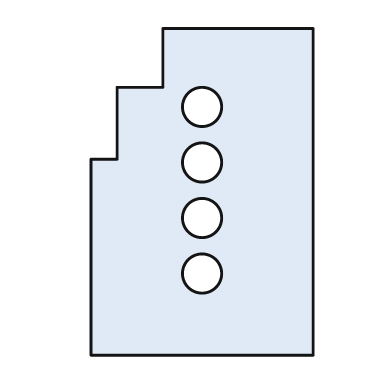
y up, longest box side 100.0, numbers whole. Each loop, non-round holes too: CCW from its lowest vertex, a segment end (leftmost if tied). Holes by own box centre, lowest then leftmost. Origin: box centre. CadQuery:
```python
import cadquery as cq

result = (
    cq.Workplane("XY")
    .moveTo(-34.0, -50.0)
    .lineTo(34.0, -50.0)
    .lineTo(34.0, 50.0)
    .lineTo(-12.0, 50.0)
    .lineTo(-12.0, 32.0)
    .lineTo(-26.0, 32.0)
    .lineTo(-26.0, 10.0)
    .lineTo(-34.0, 10.0)
    .close()
    .moveTo(0.0, -25.0)
    .circle(6.0)
    .moveTo(0.0, -8.0)
    .circle(6.0)
    .moveTo(0.0, 9.0)
    .circle(6.0)
    .moveTo(0.0, 26.0)
    .circle(6.0)
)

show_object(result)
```